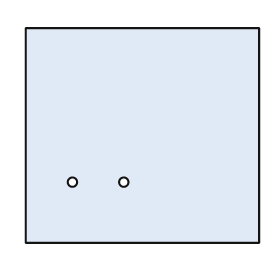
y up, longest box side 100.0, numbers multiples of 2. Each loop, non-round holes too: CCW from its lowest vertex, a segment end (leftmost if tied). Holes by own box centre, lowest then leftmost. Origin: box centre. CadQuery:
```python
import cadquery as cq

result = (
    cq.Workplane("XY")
    .moveTo(-50.0, -46.0)
    .lineTo(50.0, -46.0)
    .lineTo(50.0, 46.0)
    .lineTo(-50.0, 46.0)
    .close()
    .moveTo(-30.0, -20.0)
    .circle(2.0)
    .moveTo(-8.0, -20.0)
    .circle(2.0)
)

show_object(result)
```